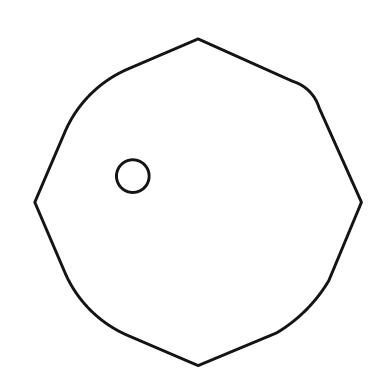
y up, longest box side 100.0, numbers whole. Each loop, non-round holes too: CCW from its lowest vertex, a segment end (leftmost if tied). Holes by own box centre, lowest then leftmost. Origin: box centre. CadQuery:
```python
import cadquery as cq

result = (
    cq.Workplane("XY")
    .moveTo(0.0, -50.0)
    .lineTo(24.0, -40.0)
    .threePointArc((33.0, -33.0), (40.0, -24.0))
    .lineTo(50.0, 0.0)
    .lineTo(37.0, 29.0)
    .threePointArc((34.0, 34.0), (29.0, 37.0))
    .lineTo(0.0, 50.0)
    .lineTo(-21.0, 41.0)
    .threePointArc((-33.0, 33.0), (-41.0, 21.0))
    .lineTo(-50.0, 0.0)
    .lineTo(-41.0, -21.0)
    .threePointArc((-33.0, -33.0), (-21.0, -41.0))
    .close()
    .moveTo(-20.0, 8.0)
    .circle(5.0)
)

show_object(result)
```